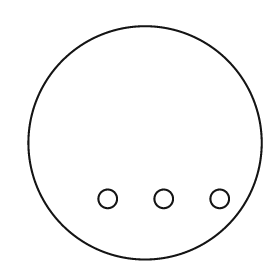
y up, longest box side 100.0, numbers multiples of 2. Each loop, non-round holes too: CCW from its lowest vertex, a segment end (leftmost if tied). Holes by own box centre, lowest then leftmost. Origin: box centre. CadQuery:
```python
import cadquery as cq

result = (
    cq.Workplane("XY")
    .moveTo(0.0, 0.0)
    .circle(50.0)
    .moveTo(-16.0, -24.0)
    .circle(4.0)
    .moveTo(8.0, -24.0)
    .circle(4.0)
    .moveTo(32.0, -24.0)
    .circle(4.0)
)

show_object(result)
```